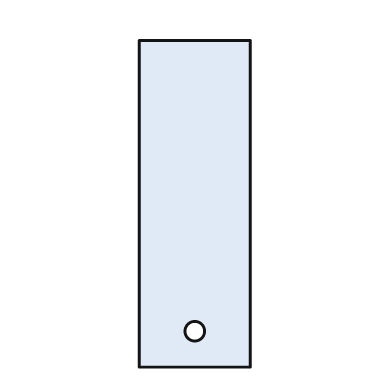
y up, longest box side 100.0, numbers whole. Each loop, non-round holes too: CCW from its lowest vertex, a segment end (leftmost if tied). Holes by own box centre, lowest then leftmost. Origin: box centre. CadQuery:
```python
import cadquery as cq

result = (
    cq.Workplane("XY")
    .moveTo(-17.0, -50.0)
    .lineTo(17.0, -50.0)
    .lineTo(17.0, 50.0)
    .lineTo(-17.0, 50.0)
    .close()
    .moveTo(0.0, -39.0)
    .circle(3.0)
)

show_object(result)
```